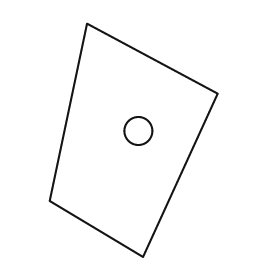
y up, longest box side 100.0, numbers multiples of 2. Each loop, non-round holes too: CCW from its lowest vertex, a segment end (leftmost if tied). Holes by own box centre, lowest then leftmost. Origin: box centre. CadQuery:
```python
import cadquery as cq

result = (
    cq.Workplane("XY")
    .moveTo(4.0, -50.0)
    .lineTo(36.0, 20.0)
    .lineTo(-20.0, 50.0)
    .lineTo(-36.0, -26.0)
    .close()
    .moveTo(2.0, 4.0)
    .circle(6.0)
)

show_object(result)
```